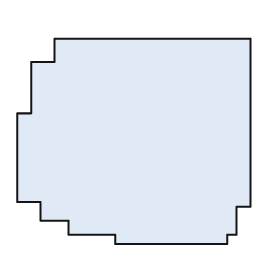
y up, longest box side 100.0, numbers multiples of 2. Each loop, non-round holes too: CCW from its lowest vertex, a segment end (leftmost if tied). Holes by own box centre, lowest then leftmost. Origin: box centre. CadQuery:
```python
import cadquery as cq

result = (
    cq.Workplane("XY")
    .moveTo(-8.0, -44.0)
    .lineTo(40.0, -44.0)
    .lineTo(40.0, -40.0)
    .lineTo(44.0, -40.0)
    .lineTo(44.0, -28.0)
    .lineTo(50.0, -28.0)
    .lineTo(50.0, 44.0)
    .lineTo(-34.0, 44.0)
    .lineTo(-34.0, 34.0)
    .lineTo(-44.0, 34.0)
    .lineTo(-44.0, 12.0)
    .lineTo(-50.0, 12.0)
    .lineTo(-50.0, -26.0)
    .lineTo(-40.0, -26.0)
    .lineTo(-40.0, -34.0)
    .lineTo(-28.0, -34.0)
    .lineTo(-28.0, -40.0)
    .lineTo(-8.0, -40.0)
    .close()
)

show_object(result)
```